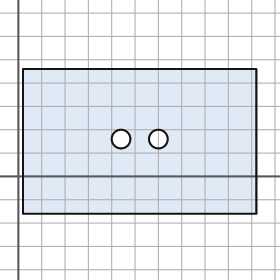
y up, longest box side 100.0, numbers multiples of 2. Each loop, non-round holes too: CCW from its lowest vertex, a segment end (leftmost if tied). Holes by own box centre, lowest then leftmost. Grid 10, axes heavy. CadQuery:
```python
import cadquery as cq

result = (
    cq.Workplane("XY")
    .moveTo(2.0, -16.0)
    .lineTo(102.0, -16.0)
    .lineTo(102.0, 46.0)
    .lineTo(2.0, 46.0)
    .close()
    .moveTo(44.0, 16.0)
    .circle(4.0)
    .moveTo(60.0, 16.0)
    .circle(4.0)
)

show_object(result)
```